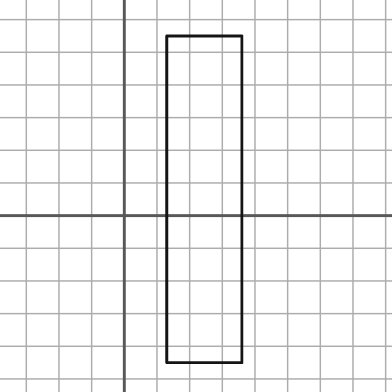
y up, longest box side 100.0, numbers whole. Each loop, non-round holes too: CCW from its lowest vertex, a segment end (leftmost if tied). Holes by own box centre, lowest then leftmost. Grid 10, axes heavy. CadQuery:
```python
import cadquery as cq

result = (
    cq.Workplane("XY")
    .moveTo(13.0, -45.0)
    .lineTo(36.0, -45.0)
    .lineTo(36.0, 55.0)
    .lineTo(13.0, 55.0)
    .close()
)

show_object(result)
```